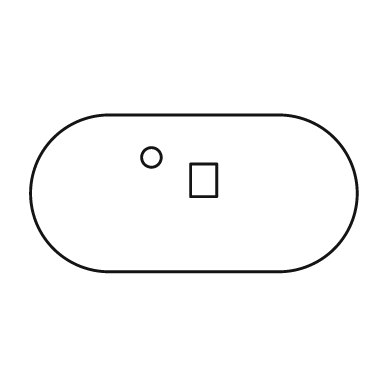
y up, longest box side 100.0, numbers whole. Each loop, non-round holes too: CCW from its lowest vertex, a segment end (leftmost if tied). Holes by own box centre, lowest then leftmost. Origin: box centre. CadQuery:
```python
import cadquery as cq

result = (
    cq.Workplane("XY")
    .moveTo(-26.0, -24.0)
    .lineTo(26.0, -24.0)
    .threePointArc((50.0, 0.0), (26.0, 24.0))
    .lineTo(-26.0, 24.0)
    .threePointArc((-50.0, 0.0), (-26.0, -24.0))
    .close()
    .moveTo(-1.0, -1.0)
    .lineTo(7.0, -1.0)
    .lineTo(7.0, 9.0)
    .lineTo(-1.0, 9.0)
    .close()
    .moveTo(-13.0, 11.0)
    .circle(3.0)
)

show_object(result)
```